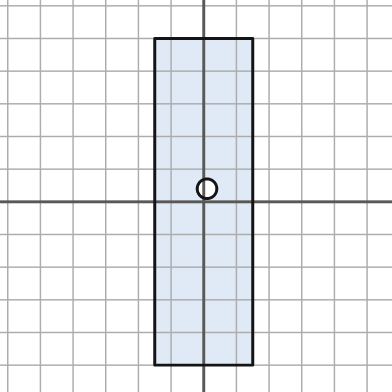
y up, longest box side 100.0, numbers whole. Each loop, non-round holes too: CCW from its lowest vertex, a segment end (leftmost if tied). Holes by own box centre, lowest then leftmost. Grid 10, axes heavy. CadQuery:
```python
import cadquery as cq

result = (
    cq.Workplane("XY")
    .moveTo(-15.0, -50.0)
    .lineTo(15.0, -50.0)
    .lineTo(15.0, 50.0)
    .lineTo(-15.0, 50.0)
    .close()
    .moveTo(1.0, 4.0)
    .circle(3.0)
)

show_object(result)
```